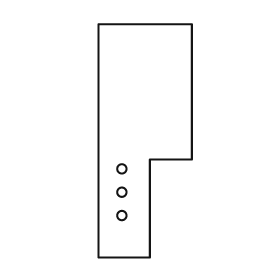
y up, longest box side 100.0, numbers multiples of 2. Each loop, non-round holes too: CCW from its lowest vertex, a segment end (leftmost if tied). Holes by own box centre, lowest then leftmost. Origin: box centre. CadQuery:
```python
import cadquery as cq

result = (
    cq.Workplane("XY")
    .moveTo(-20.0, -50.0)
    .lineTo(2.0, -50.0)
    .lineTo(2.0, -8.0)
    .lineTo(20.0, -8.0)
    .lineTo(20.0, 50.0)
    .lineTo(-20.0, 50.0)
    .close()
    .moveTo(-10.0, -32.0)
    .circle(2.0)
    .moveTo(-10.0, -22.0)
    .circle(2.0)
    .moveTo(-10.0, -12.0)
    .circle(2.0)
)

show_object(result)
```